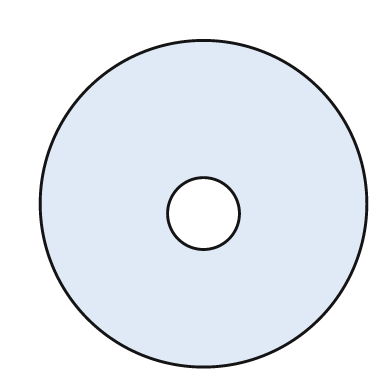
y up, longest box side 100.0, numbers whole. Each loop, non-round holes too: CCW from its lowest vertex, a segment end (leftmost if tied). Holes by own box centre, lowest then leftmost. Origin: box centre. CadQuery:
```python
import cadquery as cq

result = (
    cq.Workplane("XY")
    .moveTo(0.0, 0.0)
    .circle(50.0)
    .moveTo(0.0, -3.0)
    .circle(11.0)
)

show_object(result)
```